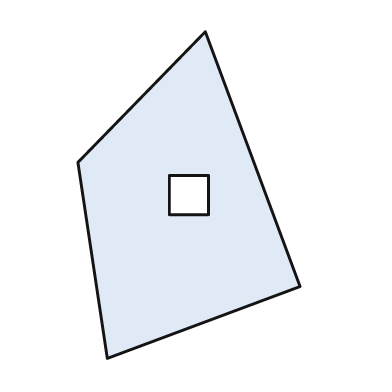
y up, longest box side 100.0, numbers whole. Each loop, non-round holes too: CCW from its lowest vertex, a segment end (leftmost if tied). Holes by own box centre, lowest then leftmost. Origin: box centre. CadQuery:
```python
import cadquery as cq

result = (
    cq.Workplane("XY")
    .moveTo(-25.0, -50.0)
    .lineTo(34.0, -28.0)
    .lineTo(5.0, 50.0)
    .lineTo(-34.0, 10.0)
    .close()
    .moveTo(-6.0, -6.0)
    .lineTo(6.0, -6.0)
    .lineTo(6.0, 6.0)
    .lineTo(-6.0, 6.0)
    .close()
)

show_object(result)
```